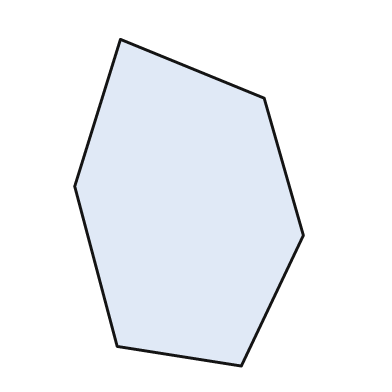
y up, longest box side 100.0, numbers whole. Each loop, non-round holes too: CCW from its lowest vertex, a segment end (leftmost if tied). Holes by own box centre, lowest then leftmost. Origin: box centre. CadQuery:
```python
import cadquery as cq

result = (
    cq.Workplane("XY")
    .moveTo(16.0, -50.0)
    .lineTo(35.0, -10.0)
    .lineTo(23.0, 32.0)
    .lineTo(-21.0, 50.0)
    .lineTo(-35.0, 5.0)
    .lineTo(-22.0, -44.0)
    .close()
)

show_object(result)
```